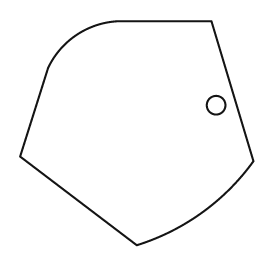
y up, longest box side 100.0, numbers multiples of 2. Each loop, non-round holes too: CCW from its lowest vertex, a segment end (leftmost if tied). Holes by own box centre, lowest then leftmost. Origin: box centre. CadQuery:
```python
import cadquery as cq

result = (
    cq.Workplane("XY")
    .moveTo(0.0, -48.0)
    .threePointArc((28.0, -34.0), (50.0, -12.0))
    .lineTo(32.0, 48.0)
    .lineTo(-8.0, 48.0)
    .threePointArc((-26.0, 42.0), (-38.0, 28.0))
    .lineTo(-50.0, -10.0)
    .close()
    .moveTo(34.0, 12.0)
    .circle(4.0)
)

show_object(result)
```